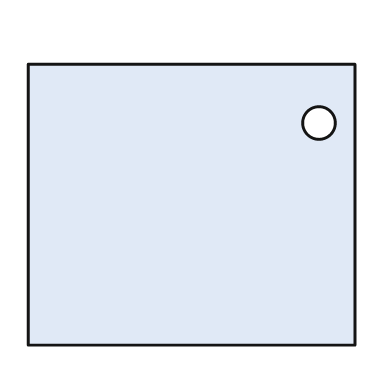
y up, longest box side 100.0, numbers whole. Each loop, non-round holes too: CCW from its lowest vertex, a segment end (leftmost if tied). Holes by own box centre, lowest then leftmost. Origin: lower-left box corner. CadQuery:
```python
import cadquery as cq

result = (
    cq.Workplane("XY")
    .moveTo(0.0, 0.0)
    .lineTo(100.0, 0.0)
    .lineTo(100.0, 86.0)
    .lineTo(0.0, 86.0)
    .close()
    .moveTo(89.0, 68.0)
    .circle(5.0)
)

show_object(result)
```